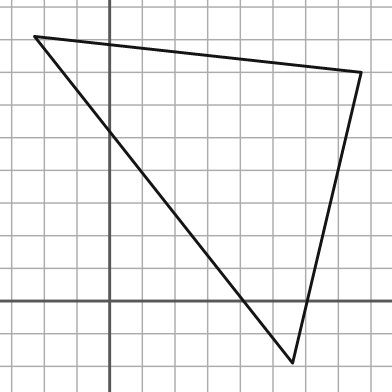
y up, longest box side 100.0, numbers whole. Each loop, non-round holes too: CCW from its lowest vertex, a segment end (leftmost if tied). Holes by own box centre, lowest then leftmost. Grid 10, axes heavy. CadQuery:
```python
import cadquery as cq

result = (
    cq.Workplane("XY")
    .moveTo(56.0, -19.0)
    .lineTo(77.0, 70.0)
    .lineTo(-23.0, 81.0)
    .close()
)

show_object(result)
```